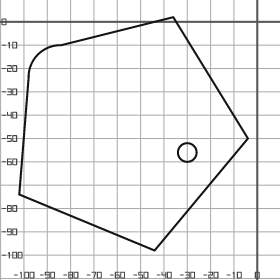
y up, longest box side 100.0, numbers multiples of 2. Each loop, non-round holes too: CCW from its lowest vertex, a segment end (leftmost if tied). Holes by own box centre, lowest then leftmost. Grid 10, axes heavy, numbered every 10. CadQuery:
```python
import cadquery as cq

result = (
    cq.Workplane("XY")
    .moveTo(-44.0, -98.0)
    .lineTo(-4.0, -50.0)
    .lineTo(-36.0, 2.0)
    .lineTo(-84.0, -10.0)
    .threePointArc((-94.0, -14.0), (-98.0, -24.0))
    .lineTo(-102.0, -74.0)
    .close()
    .moveTo(-30.0, -56.0)
    .circle(4.0)
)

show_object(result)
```